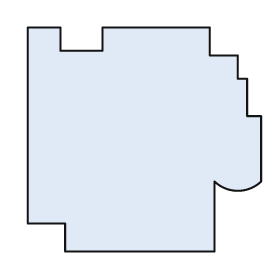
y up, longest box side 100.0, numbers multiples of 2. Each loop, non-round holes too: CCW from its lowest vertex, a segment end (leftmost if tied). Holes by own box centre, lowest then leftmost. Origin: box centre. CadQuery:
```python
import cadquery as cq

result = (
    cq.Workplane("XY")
    .moveTo(-34.0, -48.0)
    .lineTo(30.0, -48.0)
    .lineTo(30.0, -18.0)
    .threePointArc((40.0, -22.0), (50.0, -18.0))
    .lineTo(50.0, 10.0)
    .lineTo(44.0, 10.0)
    .lineTo(44.0, 26.0)
    .lineTo(40.0, 26.0)
    .lineTo(40.0, 36.0)
    .lineTo(28.0, 36.0)
    .lineTo(28.0, 48.0)
    .lineTo(-18.0, 48.0)
    .lineTo(-18.0, 38.0)
    .lineTo(-36.0, 38.0)
    .lineTo(-36.0, 48.0)
    .lineTo(-50.0, 48.0)
    .lineTo(-50.0, -36.0)
    .lineTo(-34.0, -36.0)
    .close()
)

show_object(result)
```